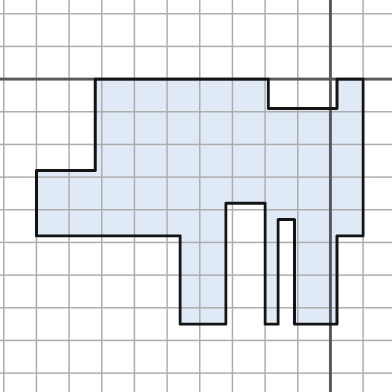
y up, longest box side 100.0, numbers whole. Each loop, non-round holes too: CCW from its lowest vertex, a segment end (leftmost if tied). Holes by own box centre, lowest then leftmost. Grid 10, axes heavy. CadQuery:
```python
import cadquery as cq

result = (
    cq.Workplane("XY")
    .moveTo(-46.0, -75.0)
    .lineTo(-32.0, -75.0)
    .lineTo(-32.0, -38.0)
    .lineTo(-20.0, -38.0)
    .lineTo(-20.0, -75.0)
    .lineTo(-16.0, -75.0)
    .lineTo(-16.0, -43.0)
    .lineTo(-11.0, -43.0)
    .lineTo(-11.0, -75.0)
    .lineTo(2.0, -75.0)
    .lineTo(2.0, -48.0)
    .lineTo(10.0, -48.0)
    .lineTo(10.0, 0.0)
    .lineTo(2.0, 0.0)
    .lineTo(2.0, -9.0)
    .lineTo(-19.0, -9.0)
    .lineTo(-19.0, 0.0)
    .lineTo(-72.0, 0.0)
    .lineTo(-72.0, -28.0)
    .lineTo(-90.0, -28.0)
    .lineTo(-90.0, -48.0)
    .lineTo(-46.0, -48.0)
    .close()
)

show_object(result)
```